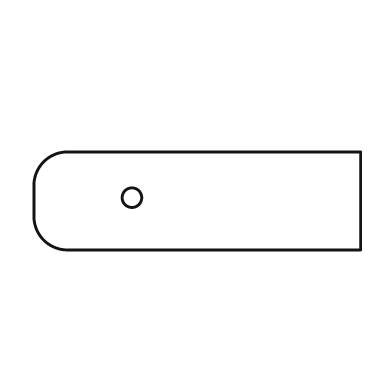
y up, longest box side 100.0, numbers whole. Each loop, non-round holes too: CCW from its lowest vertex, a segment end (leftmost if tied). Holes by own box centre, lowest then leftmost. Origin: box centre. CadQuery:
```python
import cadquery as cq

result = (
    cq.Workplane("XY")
    .moveTo(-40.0, -15.0)
    .lineTo(50.0, -15.0)
    .lineTo(50.0, 15.0)
    .lineTo(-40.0, 15.0)
    .threePointArc((-47.0, 12.0), (-50.0, 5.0))
    .lineTo(-50.0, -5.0)
    .threePointArc((-47.0, -12.0), (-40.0, -15.0))
    .close()
    .moveTo(-20.0, 1.0)
    .circle(3.0)
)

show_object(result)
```